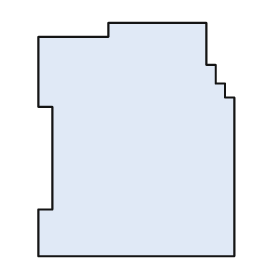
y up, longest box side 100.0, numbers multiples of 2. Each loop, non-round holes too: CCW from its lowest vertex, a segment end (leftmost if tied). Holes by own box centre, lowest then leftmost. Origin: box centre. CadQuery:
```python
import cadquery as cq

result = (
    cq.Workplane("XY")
    .moveTo(-42.0, -50.0)
    .lineTo(42.0, -50.0)
    .lineTo(42.0, 18.0)
    .lineTo(38.0, 18.0)
    .lineTo(38.0, 24.0)
    .lineTo(34.0, 24.0)
    .lineTo(34.0, 32.0)
    .lineTo(30.0, 32.0)
    .lineTo(30.0, 50.0)
    .lineTo(-12.0, 50.0)
    .lineTo(-12.0, 44.0)
    .lineTo(-42.0, 44.0)
    .lineTo(-42.0, 14.0)
    .lineTo(-36.0, 14.0)
    .lineTo(-36.0, -30.0)
    .lineTo(-42.0, -30.0)
    .close()
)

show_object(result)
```